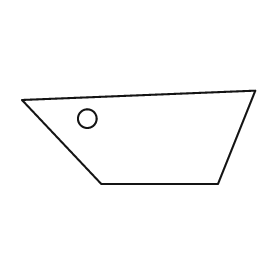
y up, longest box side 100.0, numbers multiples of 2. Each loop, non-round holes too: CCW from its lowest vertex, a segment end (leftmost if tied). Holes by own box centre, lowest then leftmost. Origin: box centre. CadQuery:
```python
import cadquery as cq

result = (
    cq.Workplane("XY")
    .moveTo(-16.0, -20.0)
    .lineTo(34.0, -20.0)
    .lineTo(50.0, 20.0)
    .lineTo(-50.0, 16.0)
    .close()
    .moveTo(-22.0, 8.0)
    .circle(4.0)
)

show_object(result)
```